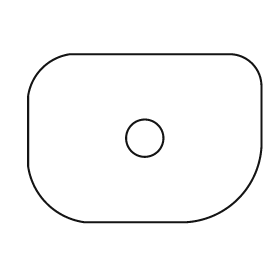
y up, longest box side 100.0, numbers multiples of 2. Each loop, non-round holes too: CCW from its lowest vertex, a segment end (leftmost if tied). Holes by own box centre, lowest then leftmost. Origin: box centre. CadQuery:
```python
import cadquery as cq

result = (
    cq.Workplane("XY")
    .moveTo(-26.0, -36.0)
    .lineTo(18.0, -36.0)
    .threePointArc((40.0, -26.0), (50.0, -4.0))
    .lineTo(50.0, 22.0)
    .threePointArc((46.0, 32.0), (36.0, 36.0))
    .lineTo(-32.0, 36.0)
    .threePointArc((-44.0, 30.0), (-50.0, 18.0))
    .lineTo(-50.0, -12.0)
    .threePointArc((-42.0, -28.0), (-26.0, -36.0))
    .close()
    .moveTo(0.0, 0.0)
    .circle(8.0)
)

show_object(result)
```